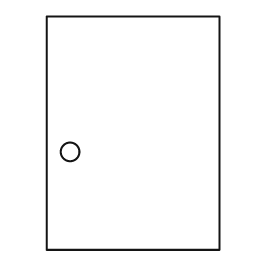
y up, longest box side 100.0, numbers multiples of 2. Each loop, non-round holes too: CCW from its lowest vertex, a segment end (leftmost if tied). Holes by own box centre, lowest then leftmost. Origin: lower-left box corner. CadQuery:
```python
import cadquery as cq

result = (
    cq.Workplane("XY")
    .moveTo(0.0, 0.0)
    .lineTo(74.0, 0.0)
    .lineTo(74.0, 100.0)
    .lineTo(0.0, 100.0)
    .close()
    .moveTo(10.0, 42.0)
    .circle(4.0)
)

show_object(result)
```